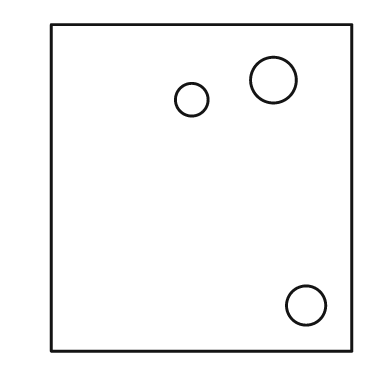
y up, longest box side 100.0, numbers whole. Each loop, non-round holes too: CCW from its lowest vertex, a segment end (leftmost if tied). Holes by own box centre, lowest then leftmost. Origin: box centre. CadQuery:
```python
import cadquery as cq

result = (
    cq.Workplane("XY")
    .moveTo(-46.0, -50.0)
    .lineTo(46.0, -50.0)
    .lineTo(46.0, 50.0)
    .lineTo(-46.0, 50.0)
    .close()
    .moveTo(32.0, -36.0)
    .circle(6.0)
    .moveTo(-3.0, 27.0)
    .circle(5.0)
    .moveTo(22.0, 33.0)
    .circle(7.0)
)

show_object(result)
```